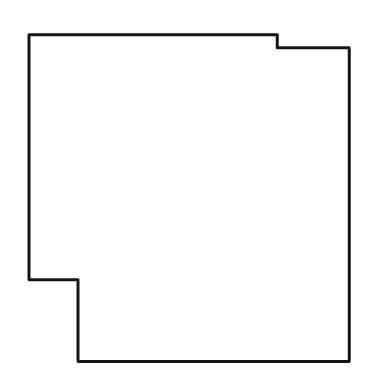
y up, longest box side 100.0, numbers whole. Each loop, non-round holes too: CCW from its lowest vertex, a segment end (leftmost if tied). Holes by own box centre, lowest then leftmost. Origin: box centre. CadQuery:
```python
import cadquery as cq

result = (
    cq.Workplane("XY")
    .moveTo(-34.0, -50.0)
    .lineTo(49.0, -50.0)
    .lineTo(49.0, 46.0)
    .lineTo(27.0, 46.0)
    .lineTo(27.0, 50.0)
    .lineTo(-49.0, 50.0)
    .lineTo(-49.0, -25.0)
    .lineTo(-34.0, -25.0)
    .close()
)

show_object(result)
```